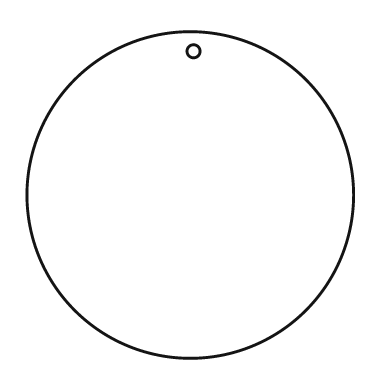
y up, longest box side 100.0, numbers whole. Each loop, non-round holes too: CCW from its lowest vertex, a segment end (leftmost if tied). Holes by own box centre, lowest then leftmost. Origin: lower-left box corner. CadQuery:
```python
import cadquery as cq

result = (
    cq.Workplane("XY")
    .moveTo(50.0, 50.0)
    .circle(50.0)
    .moveTo(51.0, 94.0)
    .circle(2.0)
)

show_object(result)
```